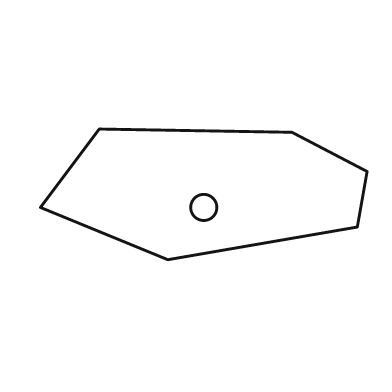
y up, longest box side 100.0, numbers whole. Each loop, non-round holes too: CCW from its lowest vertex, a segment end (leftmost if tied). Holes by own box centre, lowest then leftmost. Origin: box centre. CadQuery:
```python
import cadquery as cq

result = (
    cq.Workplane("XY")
    .moveTo(-11.0, -20.0)
    .lineTo(47.0, -10.0)
    .lineTo(50.0, 7.0)
    .lineTo(27.0, 19.0)
    .lineTo(-32.0, 20.0)
    .lineTo(-50.0, -4.0)
    .close()
    .moveTo(0.0, -4.0)
    .circle(4.0)
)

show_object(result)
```